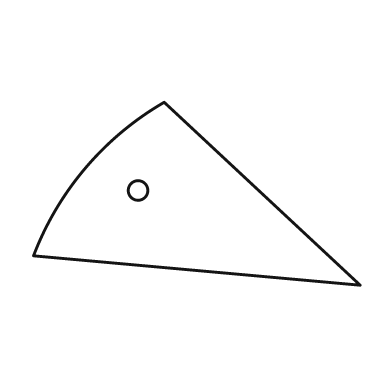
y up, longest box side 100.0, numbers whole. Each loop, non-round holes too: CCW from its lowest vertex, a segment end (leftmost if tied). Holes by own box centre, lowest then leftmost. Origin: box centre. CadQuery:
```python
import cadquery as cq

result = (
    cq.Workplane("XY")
    .moveTo(50.0, -28.0)
    .lineTo(-10.0, 28.0)
    .threePointArc((-34.0, 8.0), (-50.0, -19.0))
    .close()
    .moveTo(-18.0, 1.0)
    .circle(3.0)
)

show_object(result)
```